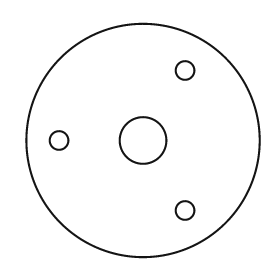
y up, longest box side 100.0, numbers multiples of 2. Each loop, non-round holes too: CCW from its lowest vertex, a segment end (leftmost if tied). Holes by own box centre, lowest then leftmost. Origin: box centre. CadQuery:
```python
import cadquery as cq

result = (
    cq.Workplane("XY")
    .moveTo(0.0, 0.0)
    .circle(50.0)
    .moveTo(18.0, -30.0)
    .circle(4.0)
    .moveTo(-36.0, 0.0)
    .circle(4.0)
    .moveTo(0.0, 0.0)
    .circle(10.0)
    .moveTo(18.0, 30.0)
    .circle(4.0)
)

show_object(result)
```